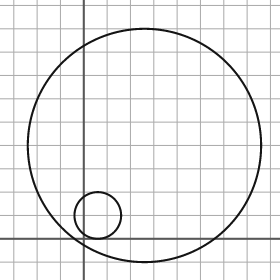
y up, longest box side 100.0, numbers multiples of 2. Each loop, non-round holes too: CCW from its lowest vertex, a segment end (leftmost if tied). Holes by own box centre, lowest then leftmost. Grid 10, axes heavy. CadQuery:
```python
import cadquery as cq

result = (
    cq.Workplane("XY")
    .moveTo(26.0, 40.0)
    .circle(50.0)
    .moveTo(6.0, 10.0)
    .circle(10.0)
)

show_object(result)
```